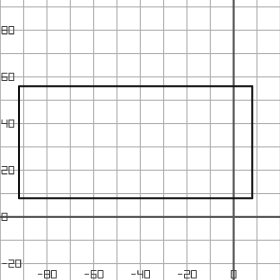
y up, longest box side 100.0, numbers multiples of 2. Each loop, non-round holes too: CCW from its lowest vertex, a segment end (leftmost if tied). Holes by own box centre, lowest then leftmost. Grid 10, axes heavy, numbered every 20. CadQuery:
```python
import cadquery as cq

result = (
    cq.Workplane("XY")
    .moveTo(-92.0, 8.0)
    .lineTo(8.0, 8.0)
    .lineTo(8.0, 56.0)
    .lineTo(-92.0, 56.0)
    .close()
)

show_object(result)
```